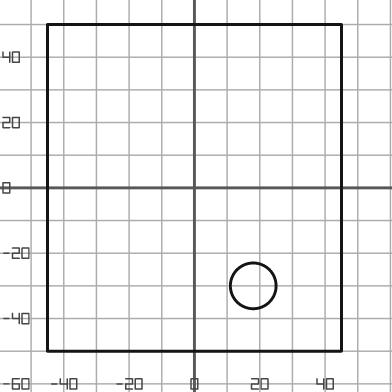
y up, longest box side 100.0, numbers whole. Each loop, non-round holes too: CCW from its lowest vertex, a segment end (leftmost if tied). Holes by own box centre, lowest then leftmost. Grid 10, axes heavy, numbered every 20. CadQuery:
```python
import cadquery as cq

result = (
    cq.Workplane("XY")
    .moveTo(-45.0, -50.0)
    .lineTo(45.0, -50.0)
    .lineTo(45.0, 50.0)
    .lineTo(-45.0, 50.0)
    .close()
    .moveTo(18.0, -30.0)
    .circle(7.0)
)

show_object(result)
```